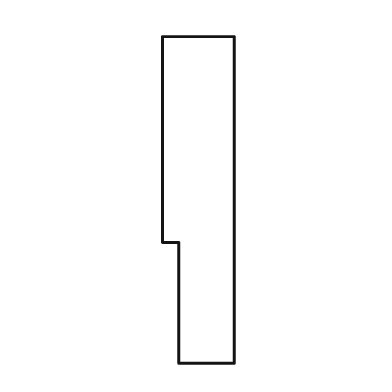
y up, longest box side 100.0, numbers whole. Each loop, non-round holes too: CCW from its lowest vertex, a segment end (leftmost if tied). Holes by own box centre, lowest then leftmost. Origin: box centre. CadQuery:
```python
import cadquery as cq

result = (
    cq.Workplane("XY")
    .moveTo(-6.0, -50.0)
    .lineTo(11.0, -50.0)
    .lineTo(11.0, 50.0)
    .lineTo(-11.0, 50.0)
    .lineTo(-11.0, -13.0)
    .lineTo(-6.0, -13.0)
    .close()
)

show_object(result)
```